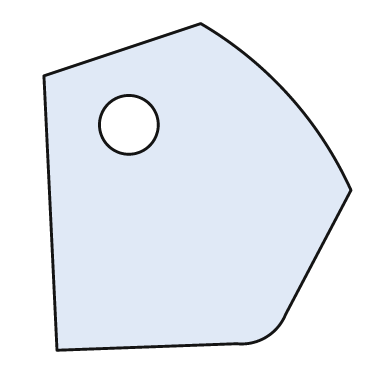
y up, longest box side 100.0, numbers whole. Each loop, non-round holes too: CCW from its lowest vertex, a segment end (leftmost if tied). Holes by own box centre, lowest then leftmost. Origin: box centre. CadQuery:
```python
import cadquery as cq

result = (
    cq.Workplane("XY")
    .moveTo(-43.0, -50.0)
    .lineTo(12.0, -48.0)
    .threePointArc((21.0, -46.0), (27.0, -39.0))
    .lineTo(47.0, -1.0)
    .threePointArc((28.0, 28.0), (1.0, 50.0))
    .lineTo(-47.0, 34.0)
    .close()
    .moveTo(-21.0, 19.0)
    .circle(9.0)
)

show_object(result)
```